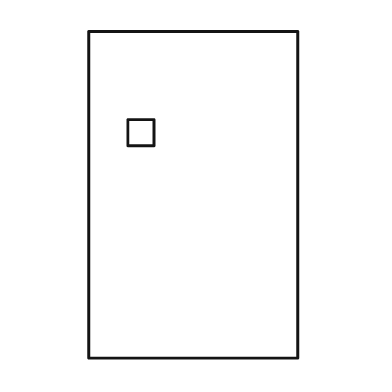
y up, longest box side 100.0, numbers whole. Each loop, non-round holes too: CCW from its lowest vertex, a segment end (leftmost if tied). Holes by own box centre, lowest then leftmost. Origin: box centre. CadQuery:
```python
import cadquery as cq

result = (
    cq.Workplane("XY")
    .moveTo(-32.0, -50.0)
    .lineTo(32.0, -50.0)
    .lineTo(32.0, 50.0)
    .lineTo(-32.0, 50.0)
    .close()
    .moveTo(-20.0, 15.0)
    .lineTo(-12.0, 15.0)
    .lineTo(-12.0, 23.0)
    .lineTo(-20.0, 23.0)
    .close()
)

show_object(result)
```